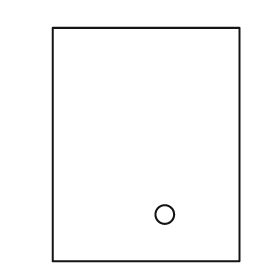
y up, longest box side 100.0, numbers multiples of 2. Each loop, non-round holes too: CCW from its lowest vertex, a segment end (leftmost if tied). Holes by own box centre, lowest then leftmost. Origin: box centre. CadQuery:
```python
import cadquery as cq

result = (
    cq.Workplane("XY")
    .moveTo(-40.0, -50.0)
    .lineTo(40.0, -50.0)
    .lineTo(40.0, 50.0)
    .lineTo(-40.0, 50.0)
    .close()
    .moveTo(8.0, -30.0)
    .circle(4.0)
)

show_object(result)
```